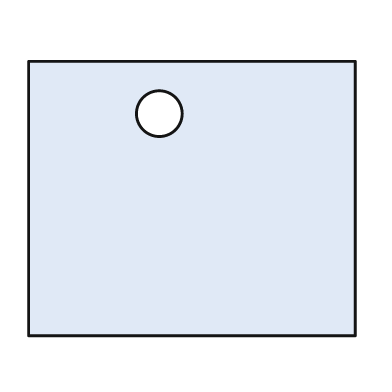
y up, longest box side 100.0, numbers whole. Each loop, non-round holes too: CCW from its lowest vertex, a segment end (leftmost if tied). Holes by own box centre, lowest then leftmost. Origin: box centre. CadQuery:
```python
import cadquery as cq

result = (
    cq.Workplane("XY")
    .moveTo(-50.0, -42.0)
    .lineTo(50.0, -42.0)
    .lineTo(50.0, 42.0)
    .lineTo(-50.0, 42.0)
    .close()
    .moveTo(-10.0, 26.0)
    .circle(7.0)
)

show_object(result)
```